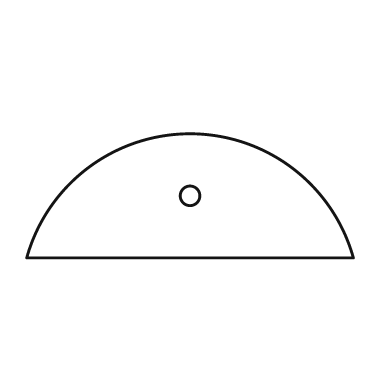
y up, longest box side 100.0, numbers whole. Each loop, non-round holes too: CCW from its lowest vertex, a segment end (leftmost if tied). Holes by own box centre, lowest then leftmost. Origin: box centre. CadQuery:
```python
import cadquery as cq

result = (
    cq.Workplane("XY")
    .moveTo(-50.0, -19.0)
    .lineTo(50.0, -19.0)
    .threePointArc((0.0, 19.0), (-50.0, -19.0))
    .close()
    .moveTo(0.0, 0.0)
    .circle(3.0)
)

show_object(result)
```